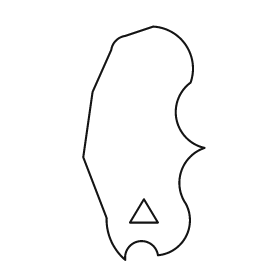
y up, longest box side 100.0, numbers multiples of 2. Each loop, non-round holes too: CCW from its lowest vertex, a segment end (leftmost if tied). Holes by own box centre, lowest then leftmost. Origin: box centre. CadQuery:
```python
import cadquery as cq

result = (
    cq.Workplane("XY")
    .moveTo(-8.0, -50.0)
    .threePointArc((-2.0, -42.0), (6.0, -48.0))
    .threePointArc((18.0, -40.0), (18.0, -26.0))
    .threePointArc((16.0, -12.0), (26.0, -2.0))
    .threePointArc((14.0, 10.0), (20.0, 26.0))
    .threePointArc((18.0, 42.0), (4.0, 50.0))
    .lineTo(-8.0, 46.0)
    .threePointArc((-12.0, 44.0), (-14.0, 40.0))
    .lineTo(-22.0, 22.0)
    .lineTo(-26.0, -6.0)
    .lineTo(-16.0, -32.0)
    .threePointArc((-14.0, -42.0), (-8.0, -50.0))
    .close()
    .moveTo(-6.0, -34.0)
    .lineTo(6.0, -34.0)
    .lineTo(0.0, -24.0)
    .close()
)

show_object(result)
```